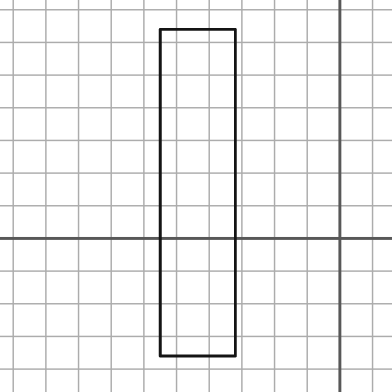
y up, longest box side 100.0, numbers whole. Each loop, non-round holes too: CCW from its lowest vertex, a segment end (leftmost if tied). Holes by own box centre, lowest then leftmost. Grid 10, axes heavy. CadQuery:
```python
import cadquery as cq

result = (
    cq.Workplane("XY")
    .moveTo(-55.0, -36.0)
    .lineTo(-32.0, -36.0)
    .lineTo(-32.0, 64.0)
    .lineTo(-55.0, 64.0)
    .close()
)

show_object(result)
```